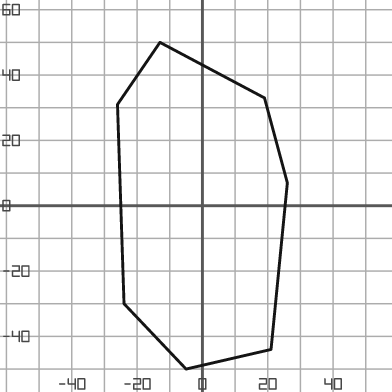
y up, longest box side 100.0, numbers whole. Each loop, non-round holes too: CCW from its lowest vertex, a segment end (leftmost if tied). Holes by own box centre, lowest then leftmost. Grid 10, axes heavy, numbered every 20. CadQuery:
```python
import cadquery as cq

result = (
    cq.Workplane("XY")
    .moveTo(-5.0, -50.0)
    .lineTo(21.0, -44.0)
    .lineTo(26.0, 7.0)
    .lineTo(19.0, 33.0)
    .lineTo(-13.0, 50.0)
    .lineTo(-26.0, 31.0)
    .lineTo(-24.0, -30.0)
    .close()
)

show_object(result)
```